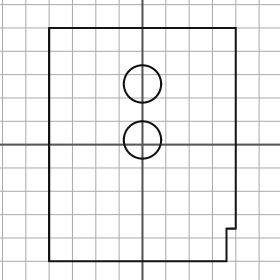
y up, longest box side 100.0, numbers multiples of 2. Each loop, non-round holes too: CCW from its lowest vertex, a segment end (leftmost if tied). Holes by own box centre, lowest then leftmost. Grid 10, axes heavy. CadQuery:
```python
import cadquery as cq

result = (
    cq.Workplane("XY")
    .moveTo(-40.0, -50.0)
    .lineTo(36.0, -50.0)
    .lineTo(36.0, -36.0)
    .lineTo(40.0, -36.0)
    .lineTo(40.0, 50.0)
    .lineTo(-40.0, 50.0)
    .close()
    .moveTo(0.0, 2.0)
    .circle(8.0)
    .moveTo(0.0, 26.0)
    .circle(8.0)
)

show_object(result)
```